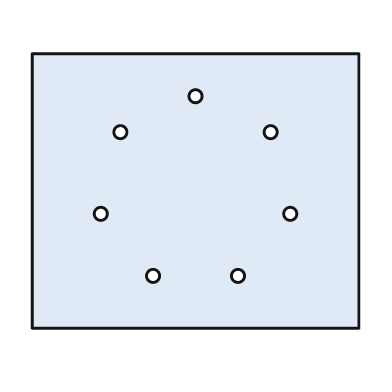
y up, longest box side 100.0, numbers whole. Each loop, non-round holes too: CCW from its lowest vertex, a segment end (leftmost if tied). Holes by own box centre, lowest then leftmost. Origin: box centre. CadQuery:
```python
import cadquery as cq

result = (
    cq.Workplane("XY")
    .moveTo(-50.0, -42.0)
    .lineTo(50.0, -42.0)
    .lineTo(50.0, 42.0)
    .lineTo(-50.0, 42.0)
    .close()
    .moveTo(-13.0, -26.0)
    .circle(2.0)
    .moveTo(13.0, -26.0)
    .circle(2.0)
    .moveTo(-29.0, -7.0)
    .circle(2.0)
    .moveTo(29.0, -7.0)
    .circle(2.0)
    .moveTo(-23.0, 18.0)
    .circle(2.0)
    .moveTo(23.0, 18.0)
    .circle(2.0)
    .moveTo(0.0, 29.0)
    .circle(2.0)
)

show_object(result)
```